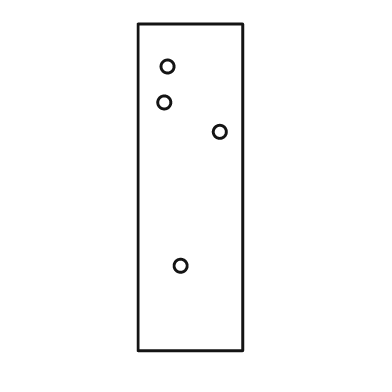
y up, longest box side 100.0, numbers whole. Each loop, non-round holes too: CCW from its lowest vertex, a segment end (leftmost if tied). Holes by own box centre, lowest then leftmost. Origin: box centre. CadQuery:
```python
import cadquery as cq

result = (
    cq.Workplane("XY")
    .moveTo(-16.0, -50.0)
    .lineTo(16.0, -50.0)
    .lineTo(16.0, 50.0)
    .lineTo(-16.0, 50.0)
    .close()
    .moveTo(-3.0, -24.0)
    .circle(2.0)
    .moveTo(9.0, 17.0)
    .circle(2.0)
    .moveTo(-8.0, 26.0)
    .circle(2.0)
    .moveTo(-7.0, 37.0)
    .circle(2.0)
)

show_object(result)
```